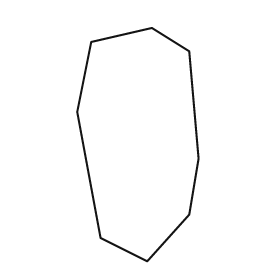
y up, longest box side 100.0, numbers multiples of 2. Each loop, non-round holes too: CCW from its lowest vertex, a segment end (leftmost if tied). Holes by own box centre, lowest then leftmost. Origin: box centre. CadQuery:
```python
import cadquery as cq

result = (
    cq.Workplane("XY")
    .moveTo(4.0, -50.0)
    .lineTo(22.0, -30.0)
    .lineTo(26.0, -6.0)
    .lineTo(22.0, 40.0)
    .lineTo(6.0, 50.0)
    .lineTo(-20.0, 44.0)
    .lineTo(-26.0, 14.0)
    .lineTo(-16.0, -40.0)
    .close()
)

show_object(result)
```